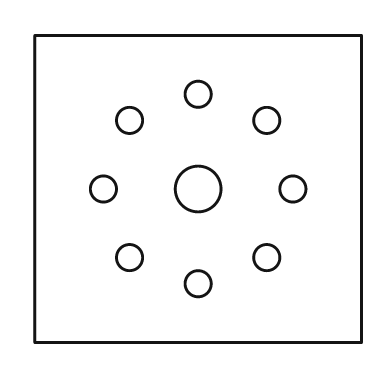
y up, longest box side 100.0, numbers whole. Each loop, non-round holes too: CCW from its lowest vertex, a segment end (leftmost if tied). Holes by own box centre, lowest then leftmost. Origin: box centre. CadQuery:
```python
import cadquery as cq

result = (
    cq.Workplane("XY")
    .moveTo(-50.0, -47.0)
    .lineTo(50.0, -47.0)
    .lineTo(50.0, 47.0)
    .lineTo(-50.0, 47.0)
    .close()
    .moveTo(0.0, -29.0)
    .circle(4.0)
    .moveTo(-21.0, -21.0)
    .circle(4.0)
    .moveTo(21.0, -21.0)
    .circle(4.0)
    .moveTo(-29.0, 0.0)
    .circle(4.0)
    .moveTo(0.0, 0.0)
    .circle(7.0)
    .moveTo(29.0, 0.0)
    .circle(4.0)
    .moveTo(-21.0, 21.0)
    .circle(4.0)
    .moveTo(21.0, 21.0)
    .circle(4.0)
    .moveTo(0.0, 29.0)
    .circle(4.0)
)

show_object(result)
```